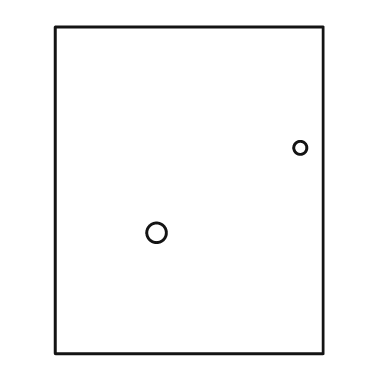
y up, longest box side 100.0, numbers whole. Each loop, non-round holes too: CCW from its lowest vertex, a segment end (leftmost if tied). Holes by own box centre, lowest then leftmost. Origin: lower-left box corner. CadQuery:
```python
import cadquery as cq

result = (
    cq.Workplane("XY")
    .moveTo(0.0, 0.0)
    .lineTo(82.0, 0.0)
    .lineTo(82.0, 100.0)
    .lineTo(0.0, 100.0)
    .close()
    .moveTo(31.0, 37.0)
    .circle(3.0)
    .moveTo(75.0, 63.0)
    .circle(2.0)
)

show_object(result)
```